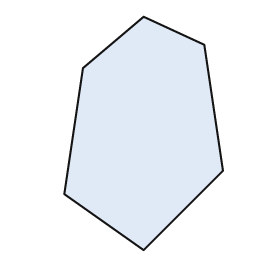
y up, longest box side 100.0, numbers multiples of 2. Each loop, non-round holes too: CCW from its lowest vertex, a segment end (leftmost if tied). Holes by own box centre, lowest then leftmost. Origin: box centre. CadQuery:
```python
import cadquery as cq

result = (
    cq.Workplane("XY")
    .moveTo(0.0, -50.0)
    .lineTo(34.0, -16.0)
    .lineTo(26.0, 38.0)
    .lineTo(0.0, 50.0)
    .lineTo(-26.0, 28.0)
    .lineTo(-34.0, -26.0)
    .close()
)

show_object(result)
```